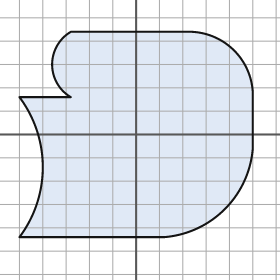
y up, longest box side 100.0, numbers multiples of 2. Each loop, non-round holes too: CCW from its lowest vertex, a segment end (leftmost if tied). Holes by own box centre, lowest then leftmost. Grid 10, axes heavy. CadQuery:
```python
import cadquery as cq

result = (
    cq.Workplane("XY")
    .moveTo(-50.0, -44.0)
    .lineTo(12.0, -44.0)
    .threePointArc((38.0, -32.0), (50.0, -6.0))
    .lineTo(50.0, 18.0)
    .threePointArc((42.0, 36.0), (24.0, 44.0))
    .lineTo(-28.0, 44.0)
    .threePointArc((-36.0, 30.0), (-28.0, 16.0))
    .lineTo(-50.0, 16.0)
    .threePointArc((-40.0, -14.0), (-50.0, -44.0))
    .close()
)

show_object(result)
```